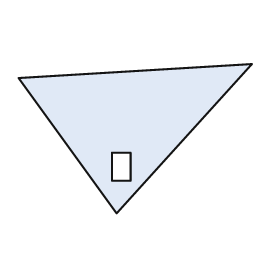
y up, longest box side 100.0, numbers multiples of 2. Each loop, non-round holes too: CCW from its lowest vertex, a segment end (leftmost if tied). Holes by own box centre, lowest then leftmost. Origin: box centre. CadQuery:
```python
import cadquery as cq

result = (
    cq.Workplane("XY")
    .moveTo(-8.0, -32.0)
    .lineTo(50.0, 32.0)
    .lineTo(-50.0, 26.0)
    .close()
    .moveTo(-10.0, -18.0)
    .lineTo(-2.0, -18.0)
    .lineTo(-2.0, -6.0)
    .lineTo(-10.0, -6.0)
    .close()
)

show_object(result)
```